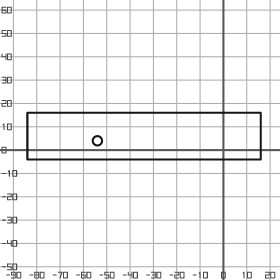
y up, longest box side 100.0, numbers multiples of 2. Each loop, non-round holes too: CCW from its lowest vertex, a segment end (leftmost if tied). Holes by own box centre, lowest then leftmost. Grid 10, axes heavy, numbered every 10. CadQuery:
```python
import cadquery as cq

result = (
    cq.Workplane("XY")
    .moveTo(-84.0, -4.0)
    .lineTo(16.0, -4.0)
    .lineTo(16.0, 16.0)
    .lineTo(-84.0, 16.0)
    .close()
    .moveTo(-54.0, 4.0)
    .circle(2.0)
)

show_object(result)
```